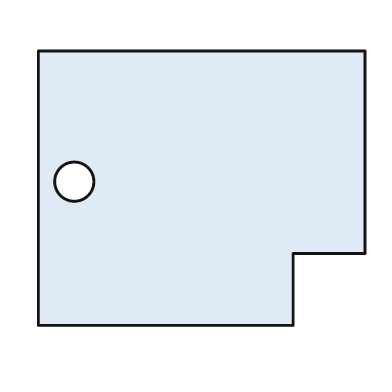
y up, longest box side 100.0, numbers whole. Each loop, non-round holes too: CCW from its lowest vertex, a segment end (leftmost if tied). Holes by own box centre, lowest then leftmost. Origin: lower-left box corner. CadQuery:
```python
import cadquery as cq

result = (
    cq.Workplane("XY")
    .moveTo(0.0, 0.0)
    .lineTo(78.0, 0.0)
    .lineTo(78.0, 22.0)
    .lineTo(100.0, 22.0)
    .lineTo(100.0, 84.0)
    .lineTo(0.0, 84.0)
    .close()
    .moveTo(11.0, 44.0)
    .circle(6.0)
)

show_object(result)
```